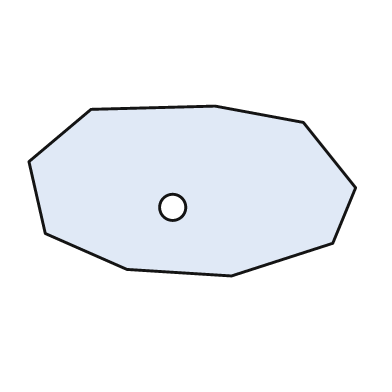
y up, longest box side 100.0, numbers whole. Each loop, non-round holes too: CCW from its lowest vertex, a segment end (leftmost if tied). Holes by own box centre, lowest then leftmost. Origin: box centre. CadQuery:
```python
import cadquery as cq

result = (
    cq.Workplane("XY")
    .moveTo(12.0, -26.0)
    .lineTo(43.0, -16.0)
    .lineTo(50.0, 1.0)
    .lineTo(34.0, 21.0)
    .lineTo(7.0, 26.0)
    .lineTo(-31.0, 25.0)
    .lineTo(-50.0, 9.0)
    .lineTo(-45.0, -13.0)
    .lineTo(-20.0, -24.0)
    .close()
    .moveTo(-6.0, -5.0)
    .circle(4.0)
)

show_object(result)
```